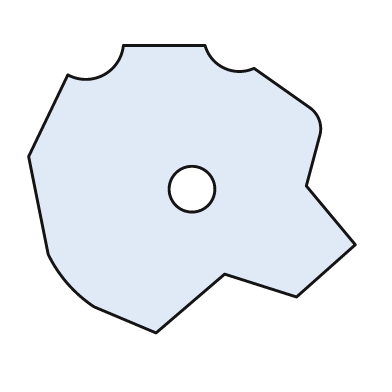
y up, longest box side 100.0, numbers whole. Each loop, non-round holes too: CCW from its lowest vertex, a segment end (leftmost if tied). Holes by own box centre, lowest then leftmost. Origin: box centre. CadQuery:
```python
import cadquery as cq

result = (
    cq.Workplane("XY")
    .moveTo(-11.0, -44.0)
    .lineTo(10.0, -26.0)
    .lineTo(32.0, -33.0)
    .lineTo(50.0, -17.0)
    .lineTo(35.0, 1.0)
    .lineTo(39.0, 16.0)
    .threePointArc((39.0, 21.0), (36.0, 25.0))
    .lineTo(19.0, 37.0)
    .threePointArc((10.0, 37.0), (4.0, 44.0))
    .lineTo(-21.0, 44.0)
    .threePointArc((-27.0, 35.0), (-38.0, 35.0))
    .lineTo(-50.0, 10.0)
    .lineTo(-44.0, -20.0)
    .threePointArc((-38.0, -29.0), (-30.0, -36.0))
    .close()
    .moveTo(0.0, 0.0)
    .circle(7.0)
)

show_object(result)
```